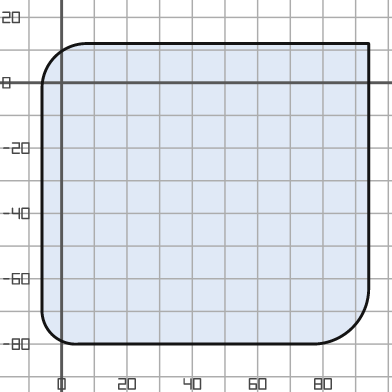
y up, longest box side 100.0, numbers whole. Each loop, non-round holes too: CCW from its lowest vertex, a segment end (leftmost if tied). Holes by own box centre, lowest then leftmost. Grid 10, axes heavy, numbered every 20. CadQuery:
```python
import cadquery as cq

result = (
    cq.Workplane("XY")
    .moveTo(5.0, -80.0)
    .lineTo(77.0, -80.0)
    .threePointArc((89.0, -75.0), (94.0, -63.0))
    .lineTo(94.0, 12.0)
    .lineTo(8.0, 12.0)
    .threePointArc((-2.0, 8.0), (-6.0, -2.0))
    .lineTo(-6.0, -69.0)
    .threePointArc((-3.0, -77.0), (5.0, -80.0))
    .close()
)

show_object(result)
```